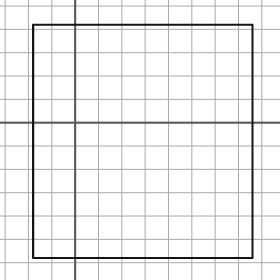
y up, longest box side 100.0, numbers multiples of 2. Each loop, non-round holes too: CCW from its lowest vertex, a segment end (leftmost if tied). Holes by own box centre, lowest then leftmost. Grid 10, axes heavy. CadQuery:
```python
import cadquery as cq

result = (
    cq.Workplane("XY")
    .moveTo(-18.0, -58.0)
    .lineTo(76.0, -58.0)
    .lineTo(76.0, 42.0)
    .lineTo(-18.0, 42.0)
    .close()
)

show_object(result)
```